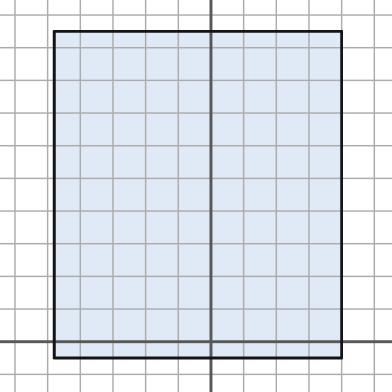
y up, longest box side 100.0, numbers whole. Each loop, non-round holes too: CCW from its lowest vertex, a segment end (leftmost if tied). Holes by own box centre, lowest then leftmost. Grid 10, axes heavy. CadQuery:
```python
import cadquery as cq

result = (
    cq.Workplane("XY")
    .moveTo(-48.0, -5.0)
    .lineTo(40.0, -5.0)
    .lineTo(40.0, 95.0)
    .lineTo(-48.0, 95.0)
    .close()
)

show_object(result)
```